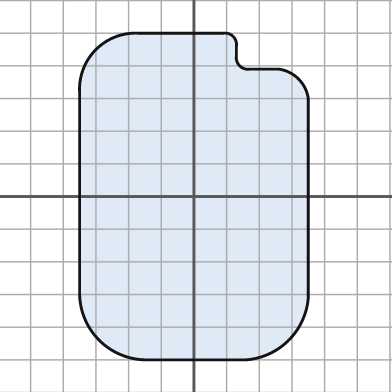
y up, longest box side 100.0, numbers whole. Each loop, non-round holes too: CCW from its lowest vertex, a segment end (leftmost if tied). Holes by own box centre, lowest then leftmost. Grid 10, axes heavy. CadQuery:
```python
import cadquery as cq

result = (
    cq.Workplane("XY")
    .moveTo(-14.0, -50.0)
    .lineTo(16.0, -50.0)
    .threePointArc((29.0, -44.0), (35.0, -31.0))
    .lineTo(35.0, 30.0)
    .threePointArc((32.0, 36.0), (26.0, 39.0))
    .lineTo(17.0, 39.0)
    .threePointArc((14.0, 40.0), (13.0, 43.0))
    .lineTo(13.0, 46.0)
    .threePointArc((12.0, 49.0), (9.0, 50.0))
    .lineTo(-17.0, 50.0)
    .threePointArc((-30.0, 45.0), (-35.0, 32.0))
    .lineTo(-35.0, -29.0)
    .threePointArc((-29.0, -44.0), (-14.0, -50.0))
    .close()
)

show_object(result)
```